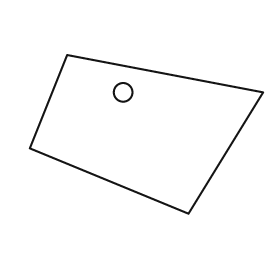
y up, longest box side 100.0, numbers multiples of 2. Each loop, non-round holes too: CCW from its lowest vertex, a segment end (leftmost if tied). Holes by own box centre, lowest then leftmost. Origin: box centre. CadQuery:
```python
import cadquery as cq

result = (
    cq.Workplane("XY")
    .moveTo(18.0, -34.0)
    .lineTo(50.0, 18.0)
    .lineTo(-34.0, 34.0)
    .lineTo(-50.0, -6.0)
    .close()
    .moveTo(-10.0, 18.0)
    .circle(4.0)
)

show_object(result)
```